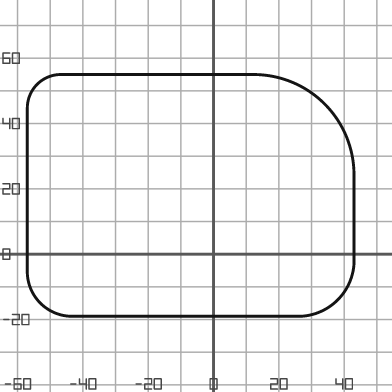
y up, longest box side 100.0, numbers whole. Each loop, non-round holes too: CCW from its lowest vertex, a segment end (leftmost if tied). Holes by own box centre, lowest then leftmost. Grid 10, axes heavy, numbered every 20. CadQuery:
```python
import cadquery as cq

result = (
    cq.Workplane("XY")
    .moveTo(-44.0, -19.0)
    .lineTo(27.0, -19.0)
    .threePointArc((38.0, -14.0), (43.0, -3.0))
    .lineTo(43.0, 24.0)
    .threePointArc((34.0, 46.0), (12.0, 55.0))
    .lineTo(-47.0, 55.0)
    .threePointArc((-54.0, 52.0), (-57.0, 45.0))
    .lineTo(-57.0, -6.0)
    .threePointArc((-53.0, -15.0), (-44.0, -19.0))
    .close()
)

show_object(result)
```